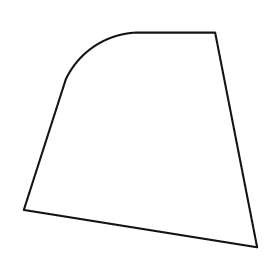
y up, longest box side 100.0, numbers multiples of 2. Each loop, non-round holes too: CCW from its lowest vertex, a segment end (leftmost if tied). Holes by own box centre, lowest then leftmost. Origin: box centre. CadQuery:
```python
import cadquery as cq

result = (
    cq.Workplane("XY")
    .moveTo(50.0, -46.0)
    .lineTo(32.0, 46.0)
    .lineTo(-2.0, 46.0)
    .threePointArc((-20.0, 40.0), (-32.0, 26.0))
    .lineTo(-50.0, -30.0)
    .close()
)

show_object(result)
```